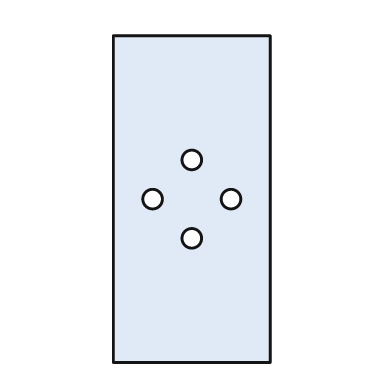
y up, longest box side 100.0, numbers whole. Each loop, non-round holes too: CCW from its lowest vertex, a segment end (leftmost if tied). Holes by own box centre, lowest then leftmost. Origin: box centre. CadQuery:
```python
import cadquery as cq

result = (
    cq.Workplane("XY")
    .moveTo(-24.0, -50.0)
    .lineTo(24.0, -50.0)
    .lineTo(24.0, 50.0)
    .lineTo(-24.0, 50.0)
    .close()
    .moveTo(0.0, -12.0)
    .circle(3.0)
    .moveTo(-12.0, 0.0)
    .circle(3.0)
    .moveTo(12.0, 0.0)
    .circle(3.0)
    .moveTo(0.0, 12.0)
    .circle(3.0)
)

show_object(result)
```